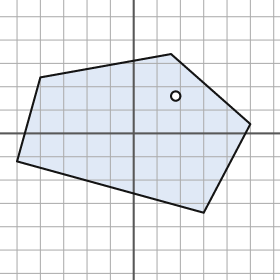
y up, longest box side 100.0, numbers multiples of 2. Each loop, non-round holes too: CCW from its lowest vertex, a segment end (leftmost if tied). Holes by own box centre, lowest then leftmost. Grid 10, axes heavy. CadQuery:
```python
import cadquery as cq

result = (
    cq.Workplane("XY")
    .moveTo(30.0, -34.0)
    .lineTo(50.0, 4.0)
    .lineTo(16.0, 34.0)
    .lineTo(-40.0, 24.0)
    .lineTo(-50.0, -12.0)
    .close()
    .moveTo(18.0, 16.0)
    .circle(2.0)
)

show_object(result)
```